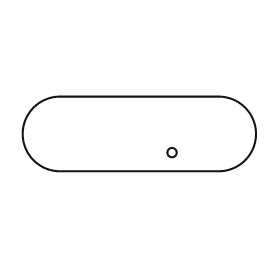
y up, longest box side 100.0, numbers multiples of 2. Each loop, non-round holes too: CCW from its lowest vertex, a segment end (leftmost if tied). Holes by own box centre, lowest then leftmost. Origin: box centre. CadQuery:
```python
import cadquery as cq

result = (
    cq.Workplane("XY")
    .moveTo(-34.0, -16.0)
    .lineTo(34.0, -16.0)
    .threePointArc((50.0, 0.0), (34.0, 16.0))
    .lineTo(-34.0, 16.0)
    .threePointArc((-50.0, 0.0), (-34.0, -16.0))
    .close()
    .moveTo(14.0, -8.0)
    .circle(2.0)
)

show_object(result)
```